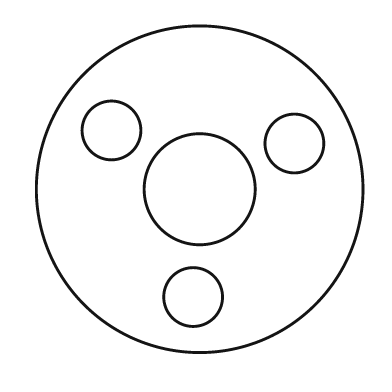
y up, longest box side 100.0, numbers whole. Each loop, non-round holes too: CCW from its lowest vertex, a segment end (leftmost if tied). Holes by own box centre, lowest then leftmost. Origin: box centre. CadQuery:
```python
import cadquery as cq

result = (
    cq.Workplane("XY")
    .moveTo(0.0, 0.0)
    .circle(50.0)
    .moveTo(-2.0, -33.0)
    .circle(9.0)
    .moveTo(0.0, 0.0)
    .circle(17.0)
    .moveTo(29.0, 14.0)
    .circle(9.0)
    .moveTo(-27.0, 18.0)
    .circle(9.0)
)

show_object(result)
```